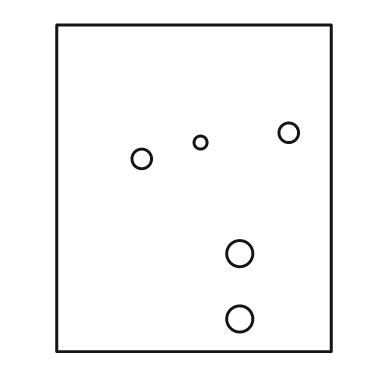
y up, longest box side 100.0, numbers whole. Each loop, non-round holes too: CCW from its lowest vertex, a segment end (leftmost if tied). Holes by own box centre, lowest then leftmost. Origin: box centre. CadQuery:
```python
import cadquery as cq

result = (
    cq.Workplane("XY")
    .moveTo(-42.0, -50.0)
    .lineTo(42.0, -50.0)
    .lineTo(42.0, 50.0)
    .lineTo(-42.0, 50.0)
    .close()
    .moveTo(14.0, -40.0)
    .circle(4.0)
    .moveTo(14.0, -20.0)
    .circle(4.0)
    .moveTo(-16.0, 9.0)
    .circle(3.0)
    .moveTo(2.0, 14.0)
    .circle(2.0)
    .moveTo(29.0, 17.0)
    .circle(3.0)
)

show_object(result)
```